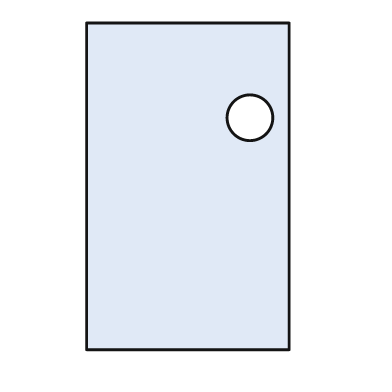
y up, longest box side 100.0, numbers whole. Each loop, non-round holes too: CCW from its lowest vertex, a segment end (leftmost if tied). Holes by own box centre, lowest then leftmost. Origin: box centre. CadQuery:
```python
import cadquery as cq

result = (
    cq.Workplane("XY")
    .moveTo(-31.0, -50.0)
    .lineTo(31.0, -50.0)
    .lineTo(31.0, 50.0)
    .lineTo(-31.0, 50.0)
    .close()
    .moveTo(19.0, 21.0)
    .circle(7.0)
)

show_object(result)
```